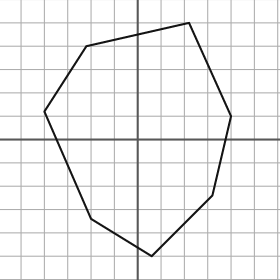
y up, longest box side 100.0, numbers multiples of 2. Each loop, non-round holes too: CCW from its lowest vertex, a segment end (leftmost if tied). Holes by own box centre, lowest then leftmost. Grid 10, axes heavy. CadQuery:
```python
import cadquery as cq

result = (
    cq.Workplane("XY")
    .moveTo(6.0, -50.0)
    .lineTo(32.0, -24.0)
    .lineTo(40.0, 10.0)
    .lineTo(22.0, 50.0)
    .lineTo(-22.0, 40.0)
    .lineTo(-40.0, 12.0)
    .lineTo(-20.0, -34.0)
    .close()
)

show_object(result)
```